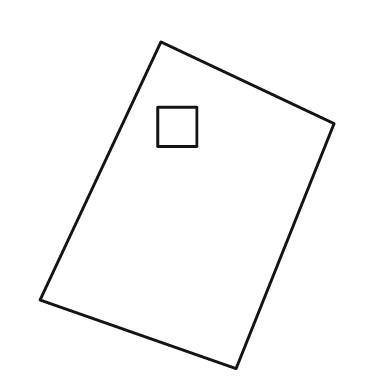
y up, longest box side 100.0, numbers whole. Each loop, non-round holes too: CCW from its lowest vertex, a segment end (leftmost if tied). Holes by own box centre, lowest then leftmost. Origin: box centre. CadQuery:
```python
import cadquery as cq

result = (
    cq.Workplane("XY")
    .moveTo(15.0, -50.0)
    .lineTo(45.0, 25.0)
    .lineTo(-8.0, 50.0)
    .lineTo(-45.0, -29.0)
    .close()
    .moveTo(-9.0, 18.0)
    .lineTo(3.0, 18.0)
    .lineTo(3.0, 30.0)
    .lineTo(-9.0, 30.0)
    .close()
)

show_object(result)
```